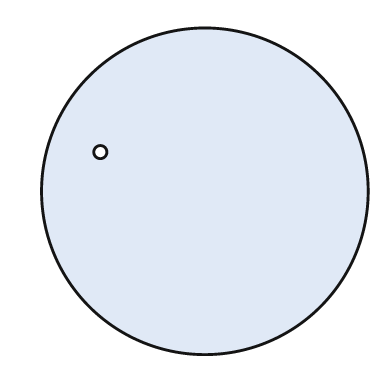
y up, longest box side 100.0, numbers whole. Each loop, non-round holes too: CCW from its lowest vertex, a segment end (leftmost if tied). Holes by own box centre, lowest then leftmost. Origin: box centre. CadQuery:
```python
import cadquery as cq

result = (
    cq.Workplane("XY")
    .moveTo(0.0, 0.0)
    .circle(50.0)
    .moveTo(-32.0, 12.0)
    .circle(2.0)
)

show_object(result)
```